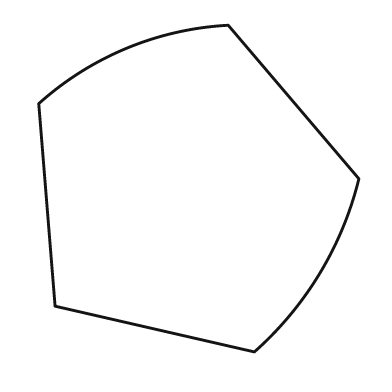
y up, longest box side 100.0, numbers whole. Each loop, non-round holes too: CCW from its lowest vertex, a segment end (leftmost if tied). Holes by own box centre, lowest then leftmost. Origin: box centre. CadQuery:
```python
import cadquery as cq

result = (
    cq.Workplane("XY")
    .moveTo(17.0, -50.0)
    .threePointArc((37.0, -26.0), (49.0, 3.0))
    .lineTo(9.0, 50.0)
    .threePointArc((-22.0, 43.0), (-49.0, 26.0))
    .lineTo(-44.0, -36.0)
    .close()
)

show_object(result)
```